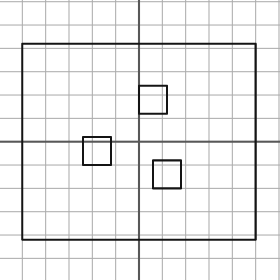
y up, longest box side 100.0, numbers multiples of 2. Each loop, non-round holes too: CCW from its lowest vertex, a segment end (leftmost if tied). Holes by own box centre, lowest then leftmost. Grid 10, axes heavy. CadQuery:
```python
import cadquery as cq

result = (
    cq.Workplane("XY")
    .moveTo(-50.0, -42.0)
    .lineTo(50.0, -42.0)
    .lineTo(50.0, 42.0)
    .lineTo(-50.0, 42.0)
    .close()
    .moveTo(6.0, -20.0)
    .lineTo(18.0, -20.0)
    .lineTo(18.0, -8.0)
    .lineTo(6.0, -8.0)
    .close()
    .moveTo(-24.0, -10.0)
    .lineTo(-12.0, -10.0)
    .lineTo(-12.0, 2.0)
    .lineTo(-24.0, 2.0)
    .close()
    .moveTo(0.0, 12.0)
    .lineTo(12.0, 12.0)
    .lineTo(12.0, 24.0)
    .lineTo(0.0, 24.0)
    .close()
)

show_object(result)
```